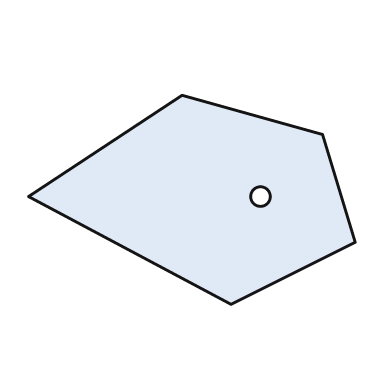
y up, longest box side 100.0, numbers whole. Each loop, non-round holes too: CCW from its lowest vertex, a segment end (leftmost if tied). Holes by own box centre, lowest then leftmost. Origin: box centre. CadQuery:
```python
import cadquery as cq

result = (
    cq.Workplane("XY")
    .moveTo(12.0, -32.0)
    .lineTo(50.0, -13.0)
    .lineTo(40.0, 20.0)
    .lineTo(-3.0, 32.0)
    .lineTo(-50.0, 1.0)
    .close()
    .moveTo(21.0, 1.0)
    .circle(3.0)
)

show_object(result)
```